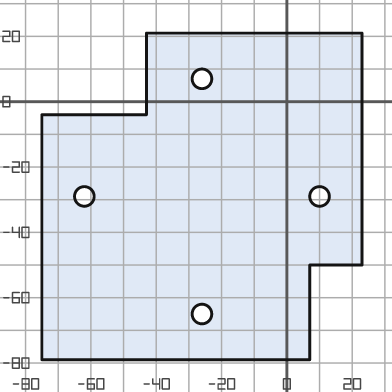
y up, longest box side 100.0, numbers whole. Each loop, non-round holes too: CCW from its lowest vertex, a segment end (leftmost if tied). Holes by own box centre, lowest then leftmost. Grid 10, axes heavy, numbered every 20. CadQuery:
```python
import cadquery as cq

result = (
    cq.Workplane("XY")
    .moveTo(-75.0, -79.0)
    .lineTo(7.0, -79.0)
    .lineTo(7.0, -50.0)
    .lineTo(23.0, -50.0)
    .lineTo(23.0, 21.0)
    .lineTo(-43.0, 21.0)
    .lineTo(-43.0, -4.0)
    .lineTo(-75.0, -4.0)
    .close()
    .moveTo(-26.0, -65.0)
    .circle(3.0)
    .moveTo(-62.0, -29.0)
    .circle(3.0)
    .moveTo(10.0, -29.0)
    .circle(3.0)
    .moveTo(-26.0, 7.0)
    .circle(3.0)
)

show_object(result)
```